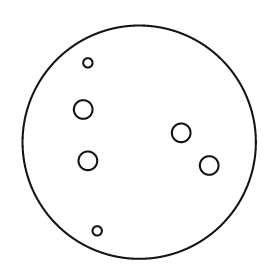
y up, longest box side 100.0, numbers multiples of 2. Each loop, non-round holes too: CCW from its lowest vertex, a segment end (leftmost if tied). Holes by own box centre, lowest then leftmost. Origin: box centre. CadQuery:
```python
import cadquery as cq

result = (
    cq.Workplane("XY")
    .moveTo(0.0, 0.0)
    .circle(50.0)
    .moveTo(-18.0, -38.0)
    .circle(2.0)
    .moveTo(30.0, -10.0)
    .circle(4.0)
    .moveTo(-22.0, -8.0)
    .circle(4.0)
    .moveTo(18.0, 4.0)
    .circle(4.0)
    .moveTo(-24.0, 14.0)
    .circle(4.0)
    .moveTo(-22.0, 34.0)
    .circle(2.0)
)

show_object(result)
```